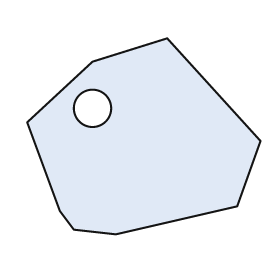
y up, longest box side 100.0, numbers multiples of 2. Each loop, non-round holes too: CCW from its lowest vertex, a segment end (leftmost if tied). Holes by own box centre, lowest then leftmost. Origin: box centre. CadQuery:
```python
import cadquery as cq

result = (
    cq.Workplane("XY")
    .moveTo(-12.0, -42.0)
    .lineTo(40.0, -30.0)
    .lineTo(50.0, -2.0)
    .lineTo(10.0, 42.0)
    .lineTo(-22.0, 32.0)
    .lineTo(-50.0, 6.0)
    .lineTo(-36.0, -32.0)
    .lineTo(-30.0, -40.0)
    .close()
    .moveTo(-22.0, 12.0)
    .circle(8.0)
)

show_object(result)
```